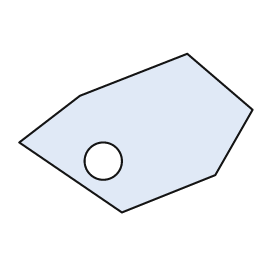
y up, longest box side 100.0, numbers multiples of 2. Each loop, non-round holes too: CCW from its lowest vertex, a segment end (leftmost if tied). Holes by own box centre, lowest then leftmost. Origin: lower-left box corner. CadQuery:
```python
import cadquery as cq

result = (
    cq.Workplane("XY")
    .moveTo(44.0, 0.0)
    .lineTo(84.0, 16.0)
    .lineTo(100.0, 44.0)
    .lineTo(72.0, 68.0)
    .lineTo(26.0, 50.0)
    .lineTo(0.0, 30.0)
    .close()
    .moveTo(36.0, 22.0)
    .circle(8.0)
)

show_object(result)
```